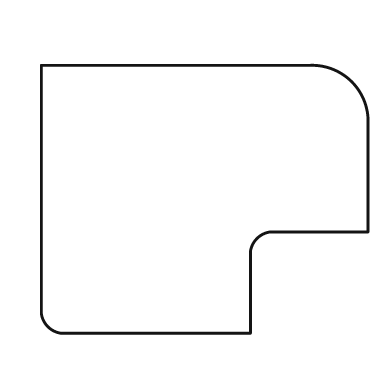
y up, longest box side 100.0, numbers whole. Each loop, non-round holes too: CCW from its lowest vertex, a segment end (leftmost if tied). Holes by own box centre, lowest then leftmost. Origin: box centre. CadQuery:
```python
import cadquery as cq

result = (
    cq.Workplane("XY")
    .moveTo(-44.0, -41.0)
    .lineTo(14.0, -41.0)
    .lineTo(14.0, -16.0)
    .threePointArc((16.0, -12.0), (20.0, -10.0))
    .lineTo(50.0, -10.0)
    .lineTo(50.0, 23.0)
    .threePointArc((45.0, 36.0), (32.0, 41.0))
    .lineTo(-50.0, 41.0)
    .lineTo(-50.0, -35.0)
    .threePointArc((-48.0, -39.0), (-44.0, -41.0))
    .close()
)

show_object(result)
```